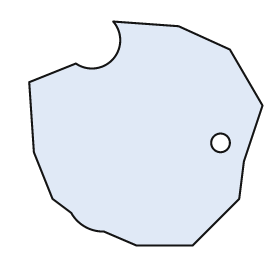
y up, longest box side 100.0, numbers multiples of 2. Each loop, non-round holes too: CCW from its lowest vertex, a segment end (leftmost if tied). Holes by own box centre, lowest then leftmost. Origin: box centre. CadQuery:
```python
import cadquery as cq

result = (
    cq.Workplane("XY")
    .moveTo(-4.0, -48.0)
    .lineTo(20.0, -48.0)
    .lineTo(40.0, -28.0)
    .lineTo(42.0, -12.0)
    .lineTo(50.0, 12.0)
    .lineTo(36.0, 36.0)
    .lineTo(14.0, 46.0)
    .lineTo(-14.0, 48.0)
    .threePointArc((-14.0, 32.0), (-30.0, 30.0))
    .lineTo(-50.0, 22.0)
    .lineTo(-48.0, -8.0)
    .lineTo(-40.0, -28.0)
    .lineTo(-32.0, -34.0)
    .threePointArc((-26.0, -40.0), (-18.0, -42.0))
    .close()
    .moveTo(32.0, -4.0)
    .circle(4.0)
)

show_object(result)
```